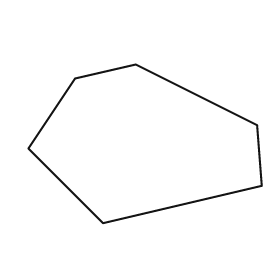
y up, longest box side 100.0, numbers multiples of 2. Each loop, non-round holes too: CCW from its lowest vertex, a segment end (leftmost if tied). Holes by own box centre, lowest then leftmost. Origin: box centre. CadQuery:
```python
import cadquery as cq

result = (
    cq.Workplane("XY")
    .moveTo(-18.0, -34.0)
    .lineTo(50.0, -18.0)
    .lineTo(48.0, 8.0)
    .lineTo(-4.0, 34.0)
    .lineTo(-30.0, 28.0)
    .lineTo(-50.0, -2.0)
    .close()
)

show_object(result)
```